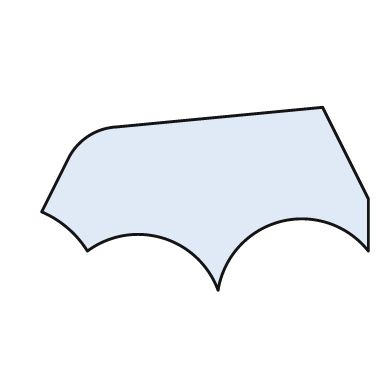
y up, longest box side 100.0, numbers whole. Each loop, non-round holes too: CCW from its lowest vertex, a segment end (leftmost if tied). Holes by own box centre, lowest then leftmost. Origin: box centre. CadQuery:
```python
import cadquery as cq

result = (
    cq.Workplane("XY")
    .moveTo(4.0, -28.0)
    .threePointArc((23.0, -7.0), (50.0, -16.0))
    .lineTo(50.0, 0.0)
    .lineTo(36.0, 28.0)
    .lineTo(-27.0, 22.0)
    .threePointArc((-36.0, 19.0), (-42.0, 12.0))
    .lineTo(-50.0, -4.0)
    .threePointArc((-42.0, -9.0), (-36.0, -16.0))
    .threePointArc((-13.0, -12.0), (4.0, -28.0))
    .close()
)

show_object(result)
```